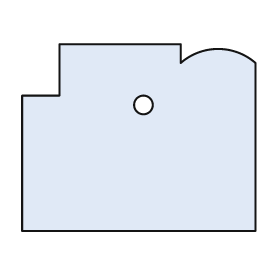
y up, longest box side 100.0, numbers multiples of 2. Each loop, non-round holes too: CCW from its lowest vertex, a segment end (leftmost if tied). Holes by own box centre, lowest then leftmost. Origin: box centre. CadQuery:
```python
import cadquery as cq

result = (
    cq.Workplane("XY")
    .moveTo(-50.0, -40.0)
    .lineTo(50.0, -40.0)
    .lineTo(50.0, 32.0)
    .threePointArc((34.0, 38.0), (18.0, 32.0))
    .lineTo(18.0, 40.0)
    .lineTo(-34.0, 40.0)
    .lineTo(-34.0, 18.0)
    .lineTo(-50.0, 18.0)
    .close()
    .moveTo(2.0, 14.0)
    .circle(4.0)
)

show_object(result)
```